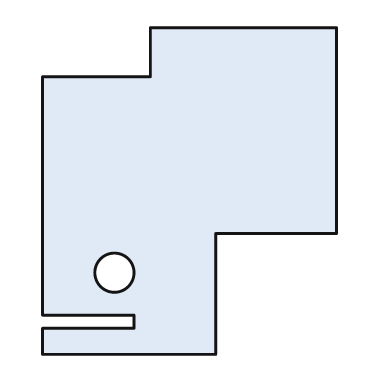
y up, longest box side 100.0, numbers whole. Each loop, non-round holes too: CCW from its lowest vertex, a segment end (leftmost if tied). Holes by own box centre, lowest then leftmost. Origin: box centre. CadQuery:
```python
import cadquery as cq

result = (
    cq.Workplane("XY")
    .moveTo(-45.0, -50.0)
    .lineTo(8.0, -50.0)
    .lineTo(8.0, -13.0)
    .lineTo(45.0, -13.0)
    .lineTo(45.0, 50.0)
    .lineTo(-12.0, 50.0)
    .lineTo(-12.0, 35.0)
    .lineTo(-45.0, 35.0)
    .lineTo(-45.0, -38.0)
    .lineTo(-17.0, -38.0)
    .lineTo(-17.0, -42.0)
    .lineTo(-45.0, -42.0)
    .close()
    .moveTo(-23.0, -25.0)
    .circle(6.0)
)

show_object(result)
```